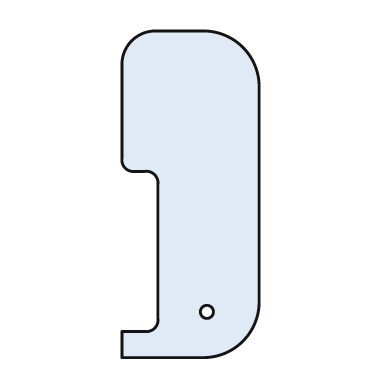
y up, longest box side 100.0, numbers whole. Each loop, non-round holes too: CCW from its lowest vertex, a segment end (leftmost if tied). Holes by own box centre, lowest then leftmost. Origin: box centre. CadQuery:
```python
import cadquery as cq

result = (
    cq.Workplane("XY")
    .moveTo(-21.0, -50.0)
    .lineTo(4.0, -50.0)
    .threePointArc((16.0, -45.0), (21.0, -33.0))
    .lineTo(21.0, 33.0)
    .threePointArc((16.0, 45.0), (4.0, 50.0))
    .lineTo(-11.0, 50.0)
    .threePointArc((-18.0, 47.0), (-21.0, 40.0))
    .lineTo(-21.0, 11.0)
    .threePointArc((-20.0, 8.0), (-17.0, 7.0))
    .lineTo(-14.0, 7.0)
    .threePointArc((-11.0, 6.0), (-10.0, 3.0))
    .lineTo(-10.0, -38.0)
    .threePointArc((-11.0, -41.0), (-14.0, -42.0))
    .lineTo(-21.0, -42.0)
    .close()
    .moveTo(5.0, -36.0)
    .circle(2.0)
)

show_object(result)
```